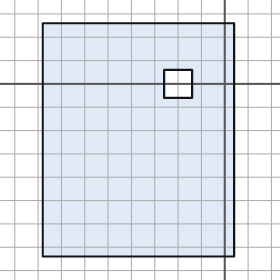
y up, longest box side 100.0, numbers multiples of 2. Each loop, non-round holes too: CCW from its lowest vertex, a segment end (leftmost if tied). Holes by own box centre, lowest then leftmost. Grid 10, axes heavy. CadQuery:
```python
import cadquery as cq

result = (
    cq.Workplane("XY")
    .moveTo(-78.0, -74.0)
    .lineTo(4.0, -74.0)
    .lineTo(4.0, 26.0)
    .lineTo(-78.0, 26.0)
    .close()
    .moveTo(-26.0, -6.0)
    .lineTo(-14.0, -6.0)
    .lineTo(-14.0, 6.0)
    .lineTo(-26.0, 6.0)
    .close()
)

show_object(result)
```